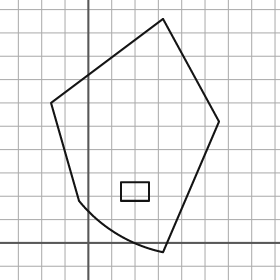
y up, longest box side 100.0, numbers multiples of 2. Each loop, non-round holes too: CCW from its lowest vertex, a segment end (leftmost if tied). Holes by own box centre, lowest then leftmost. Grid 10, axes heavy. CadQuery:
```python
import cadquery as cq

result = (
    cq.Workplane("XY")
    .moveTo(32.0, -4.0)
    .lineTo(56.0, 52.0)
    .lineTo(32.0, 96.0)
    .lineTo(-16.0, 60.0)
    .lineTo(-4.0, 18.0)
    .threePointArc((12.0, 4.0), (32.0, -4.0))
    .close()
    .moveTo(14.0, 18.0)
    .lineTo(26.0, 18.0)
    .lineTo(26.0, 26.0)
    .lineTo(14.0, 26.0)
    .close()
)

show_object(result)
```